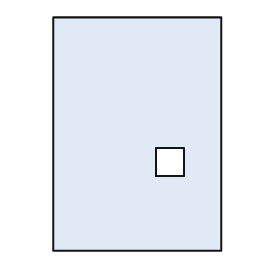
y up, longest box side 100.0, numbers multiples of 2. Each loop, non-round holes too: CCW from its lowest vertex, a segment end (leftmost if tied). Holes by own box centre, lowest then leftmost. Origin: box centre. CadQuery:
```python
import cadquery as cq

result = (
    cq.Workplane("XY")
    .moveTo(-36.0, -50.0)
    .lineTo(36.0, -50.0)
    .lineTo(36.0, 50.0)
    .lineTo(-36.0, 50.0)
    .close()
    .moveTo(8.0, -18.0)
    .lineTo(20.0, -18.0)
    .lineTo(20.0, -6.0)
    .lineTo(8.0, -6.0)
    .close()
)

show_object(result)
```